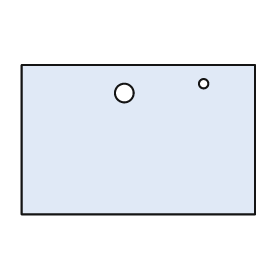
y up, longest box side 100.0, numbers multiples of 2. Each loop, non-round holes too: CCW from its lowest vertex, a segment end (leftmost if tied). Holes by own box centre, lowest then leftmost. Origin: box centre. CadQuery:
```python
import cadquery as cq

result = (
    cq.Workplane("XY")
    .moveTo(-50.0, -32.0)
    .lineTo(50.0, -32.0)
    .lineTo(50.0, 32.0)
    .lineTo(-50.0, 32.0)
    .close()
    .moveTo(-6.0, 20.0)
    .circle(4.0)
    .moveTo(28.0, 24.0)
    .circle(2.0)
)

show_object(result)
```